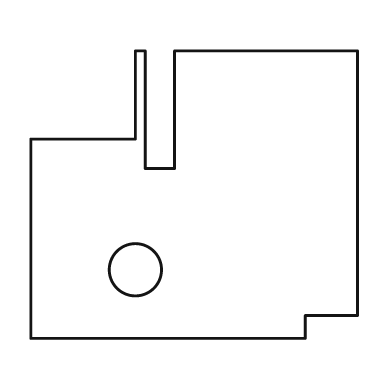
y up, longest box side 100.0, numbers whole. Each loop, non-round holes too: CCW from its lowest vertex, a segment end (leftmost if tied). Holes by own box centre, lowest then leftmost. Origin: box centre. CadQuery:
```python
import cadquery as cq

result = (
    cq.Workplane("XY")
    .moveTo(-50.0, -44.0)
    .lineTo(34.0, -44.0)
    .lineTo(34.0, -37.0)
    .lineTo(50.0, -37.0)
    .lineTo(50.0, 44.0)
    .lineTo(-6.0, 44.0)
    .lineTo(-6.0, 8.0)
    .lineTo(-15.0, 8.0)
    .lineTo(-15.0, 44.0)
    .lineTo(-18.0, 44.0)
    .lineTo(-18.0, 17.0)
    .lineTo(-50.0, 17.0)
    .close()
    .moveTo(-18.0, -23.0)
    .circle(8.0)
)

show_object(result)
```